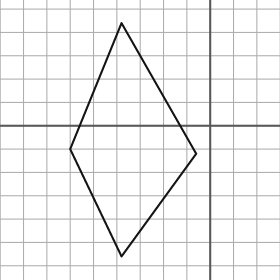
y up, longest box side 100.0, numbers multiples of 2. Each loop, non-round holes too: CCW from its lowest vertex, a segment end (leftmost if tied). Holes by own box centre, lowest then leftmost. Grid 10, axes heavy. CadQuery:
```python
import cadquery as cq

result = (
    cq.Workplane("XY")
    .moveTo(-38.0, -56.0)
    .lineTo(-6.0, -12.0)
    .lineTo(-38.0, 44.0)
    .lineTo(-60.0, -10.0)
    .close()
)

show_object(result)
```